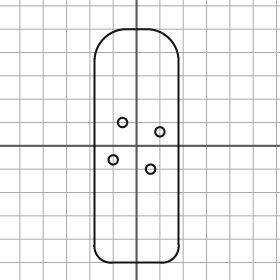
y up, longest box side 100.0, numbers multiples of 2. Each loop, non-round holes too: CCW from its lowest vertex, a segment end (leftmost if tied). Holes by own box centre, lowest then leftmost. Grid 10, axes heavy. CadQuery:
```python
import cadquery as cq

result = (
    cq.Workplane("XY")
    .moveTo(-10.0, -50.0)
    .lineTo(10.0, -50.0)
    .threePointArc((16.0, -48.0), (18.0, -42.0))
    .lineTo(18.0, 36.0)
    .threePointArc((14.0, 46.0), (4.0, 50.0))
    .lineTo(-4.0, 50.0)
    .threePointArc((-14.0, 46.0), (-18.0, 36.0))
    .lineTo(-18.0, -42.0)
    .threePointArc((-16.0, -48.0), (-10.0, -50.0))
    .close()
    .moveTo(6.0, -10.0)
    .circle(2.0)
    .moveTo(-10.0, -6.0)
    .circle(2.0)
    .moveTo(10.0, 6.0)
    .circle(2.0)
    .moveTo(-6.0, 10.0)
    .circle(2.0)
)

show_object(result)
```